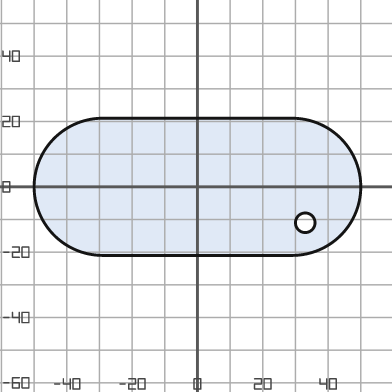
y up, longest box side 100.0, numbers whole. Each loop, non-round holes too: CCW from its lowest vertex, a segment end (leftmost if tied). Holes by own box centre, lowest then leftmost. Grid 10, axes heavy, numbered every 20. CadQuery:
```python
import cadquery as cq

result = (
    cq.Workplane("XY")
    .moveTo(-29.0, -21.0)
    .lineTo(29.0, -21.0)
    .threePointArc((50.0, 0.0), (29.0, 21.0))
    .lineTo(-29.0, 21.0)
    .threePointArc((-50.0, 0.0), (-29.0, -21.0))
    .close()
    .moveTo(33.0, -11.0)
    .circle(3.0)
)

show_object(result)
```